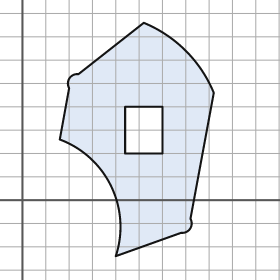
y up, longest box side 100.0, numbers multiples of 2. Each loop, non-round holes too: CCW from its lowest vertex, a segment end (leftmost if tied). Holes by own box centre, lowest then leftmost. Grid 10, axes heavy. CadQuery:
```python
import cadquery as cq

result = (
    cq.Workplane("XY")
    .moveTo(40.0, -24.0)
    .lineTo(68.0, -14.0)
    .threePointArc((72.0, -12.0), (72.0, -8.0))
    .lineTo(82.0, 46.0)
    .threePointArc((70.0, 64.0), (52.0, 76.0))
    .lineTo(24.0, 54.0)
    .threePointArc((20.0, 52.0), (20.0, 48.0))
    .lineTo(16.0, 26.0)
    .threePointArc((38.0, 6.0), (40.0, -24.0))
    .close()
    .moveTo(44.0, 20.0)
    .lineTo(60.0, 20.0)
    .lineTo(60.0, 40.0)
    .lineTo(44.0, 40.0)
    .close()
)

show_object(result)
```